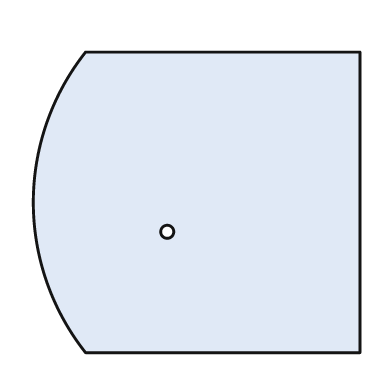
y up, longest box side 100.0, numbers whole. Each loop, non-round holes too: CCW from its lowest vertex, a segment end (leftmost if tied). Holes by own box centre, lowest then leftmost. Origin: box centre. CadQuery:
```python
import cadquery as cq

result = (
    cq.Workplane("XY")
    .moveTo(-34.0, -46.0)
    .lineTo(50.0, -46.0)
    .lineTo(50.0, 46.0)
    .lineTo(-34.0, 46.0)
    .threePointArc((-50.0, 0.0), (-34.0, -46.0))
    .close()
    .moveTo(-9.0, -9.0)
    .circle(2.0)
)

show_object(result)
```